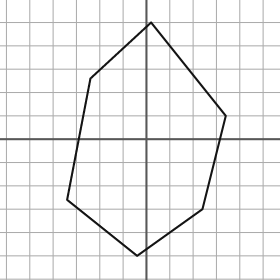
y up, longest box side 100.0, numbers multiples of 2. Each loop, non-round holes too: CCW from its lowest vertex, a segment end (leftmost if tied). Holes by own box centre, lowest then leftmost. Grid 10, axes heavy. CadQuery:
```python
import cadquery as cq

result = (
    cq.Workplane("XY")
    .moveTo(-4.0, -50.0)
    .lineTo(24.0, -30.0)
    .lineTo(34.0, 10.0)
    .lineTo(2.0, 50.0)
    .lineTo(-24.0, 26.0)
    .lineTo(-34.0, -26.0)
    .close()
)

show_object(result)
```